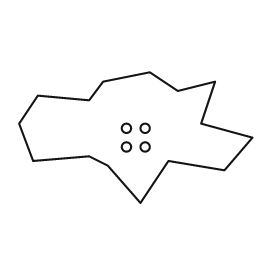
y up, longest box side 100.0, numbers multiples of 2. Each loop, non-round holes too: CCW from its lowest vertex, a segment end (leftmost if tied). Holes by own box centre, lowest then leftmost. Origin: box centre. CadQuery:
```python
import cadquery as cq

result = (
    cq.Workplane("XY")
    .moveTo(2.0, -28.0)
    .lineTo(14.0, -10.0)
    .lineTo(38.0, -14.0)
    .lineTo(50.0, 0.0)
    .lineTo(28.0, 6.0)
    .lineTo(34.0, 24.0)
    .lineTo(18.0, 20.0)
    .lineTo(6.0, 28.0)
    .lineTo(-14.0, 24.0)
    .lineTo(-20.0, 16.0)
    .lineTo(-42.0, 18.0)
    .lineTo(-50.0, 6.0)
    .lineTo(-44.0, -10.0)
    .lineTo(-20.0, -8.0)
    .lineTo(-12.0, -12.0)
    .close()
    .moveTo(-4.0, -4.0)
    .circle(2.0)
    .moveTo(4.0, -4.0)
    .circle(2.0)
    .moveTo(-4.0, 4.0)
    .circle(2.0)
    .moveTo(4.0, 4.0)
    .circle(2.0)
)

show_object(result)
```